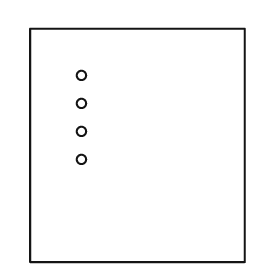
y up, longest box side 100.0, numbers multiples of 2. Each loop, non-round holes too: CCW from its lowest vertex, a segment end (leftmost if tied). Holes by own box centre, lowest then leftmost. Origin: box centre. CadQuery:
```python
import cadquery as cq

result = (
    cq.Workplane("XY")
    .moveTo(-46.0, -50.0)
    .lineTo(46.0, -50.0)
    .lineTo(46.0, 50.0)
    .lineTo(-46.0, 50.0)
    .close()
    .moveTo(-24.0, -6.0)
    .circle(2.0)
    .moveTo(-24.0, 6.0)
    .circle(2.0)
    .moveTo(-24.0, 18.0)
    .circle(2.0)
    .moveTo(-24.0, 30.0)
    .circle(2.0)
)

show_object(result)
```